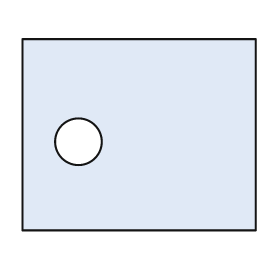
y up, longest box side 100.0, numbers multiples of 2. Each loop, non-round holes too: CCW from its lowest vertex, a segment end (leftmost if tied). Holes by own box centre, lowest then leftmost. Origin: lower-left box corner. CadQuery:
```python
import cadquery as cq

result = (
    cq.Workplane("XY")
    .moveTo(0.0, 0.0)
    .lineTo(100.0, 0.0)
    .lineTo(100.0, 82.0)
    .lineTo(0.0, 82.0)
    .close()
    .moveTo(24.0, 38.0)
    .circle(10.0)
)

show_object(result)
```